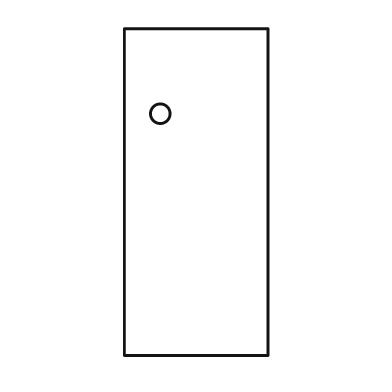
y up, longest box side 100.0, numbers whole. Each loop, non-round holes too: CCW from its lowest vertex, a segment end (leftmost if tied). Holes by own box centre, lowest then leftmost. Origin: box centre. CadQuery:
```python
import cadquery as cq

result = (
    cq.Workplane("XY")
    .moveTo(-22.0, -50.0)
    .lineTo(22.0, -50.0)
    .lineTo(22.0, 50.0)
    .lineTo(-22.0, 50.0)
    .close()
    .moveTo(-11.0, 24.0)
    .circle(3.0)
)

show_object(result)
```